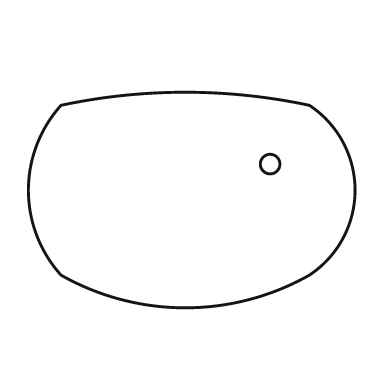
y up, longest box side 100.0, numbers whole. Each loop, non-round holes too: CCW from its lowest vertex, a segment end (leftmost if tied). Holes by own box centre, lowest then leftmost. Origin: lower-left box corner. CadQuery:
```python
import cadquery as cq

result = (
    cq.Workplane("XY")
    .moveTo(10.0, 10.0)
    .threePointArc((48.0, 0.0), (86.0, 10.0))
    .threePointArc((100.0, 36.0), (86.0, 62.0))
    .threePointArc((48.0, 66.0), (10.0, 62.0))
    .threePointArc((0.0, 36.0), (10.0, 10.0))
    .close()
    .moveTo(74.0, 44.0)
    .circle(3.0)
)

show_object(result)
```